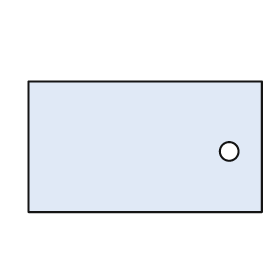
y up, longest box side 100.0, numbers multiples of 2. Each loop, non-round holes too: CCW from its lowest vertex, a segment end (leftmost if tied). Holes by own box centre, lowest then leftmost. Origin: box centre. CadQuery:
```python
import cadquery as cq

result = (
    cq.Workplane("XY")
    .moveTo(-50.0, -28.0)
    .lineTo(50.0, -28.0)
    .lineTo(50.0, 28.0)
    .lineTo(-50.0, 28.0)
    .close()
    .moveTo(36.0, -2.0)
    .circle(4.0)
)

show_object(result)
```